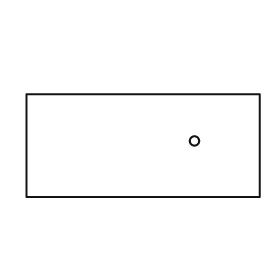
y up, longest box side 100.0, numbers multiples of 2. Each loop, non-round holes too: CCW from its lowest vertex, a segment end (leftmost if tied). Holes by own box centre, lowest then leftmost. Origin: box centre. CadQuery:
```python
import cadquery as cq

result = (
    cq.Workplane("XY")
    .moveTo(-50.0, -22.0)
    .lineTo(50.0, -22.0)
    .lineTo(50.0, 22.0)
    .lineTo(-50.0, 22.0)
    .close()
    .moveTo(22.0, 2.0)
    .circle(2.0)
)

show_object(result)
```